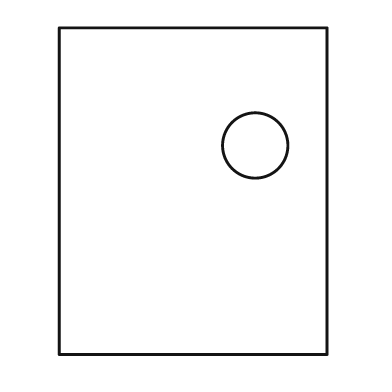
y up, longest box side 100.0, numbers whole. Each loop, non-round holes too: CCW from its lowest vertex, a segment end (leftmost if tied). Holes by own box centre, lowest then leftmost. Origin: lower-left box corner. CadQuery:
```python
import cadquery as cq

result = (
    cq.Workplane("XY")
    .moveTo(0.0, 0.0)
    .lineTo(82.0, 0.0)
    .lineTo(82.0, 100.0)
    .lineTo(0.0, 100.0)
    .close()
    .moveTo(60.0, 64.0)
    .circle(10.0)
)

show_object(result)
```